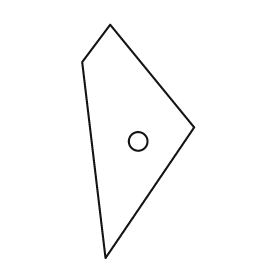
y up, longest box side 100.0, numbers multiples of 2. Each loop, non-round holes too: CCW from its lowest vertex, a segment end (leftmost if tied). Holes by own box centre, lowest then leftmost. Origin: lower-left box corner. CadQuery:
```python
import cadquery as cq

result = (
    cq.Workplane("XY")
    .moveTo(10.0, 0.0)
    .lineTo(48.0, 56.0)
    .lineTo(12.0, 100.0)
    .lineTo(0.0, 84.0)
    .close()
    .moveTo(24.0, 50.0)
    .circle(4.0)
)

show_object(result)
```